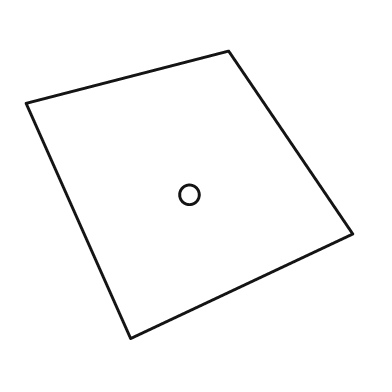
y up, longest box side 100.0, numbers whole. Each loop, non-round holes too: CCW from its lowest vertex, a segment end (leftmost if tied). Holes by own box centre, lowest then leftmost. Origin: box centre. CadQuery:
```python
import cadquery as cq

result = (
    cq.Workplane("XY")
    .moveTo(-18.0, -44.0)
    .lineTo(50.0, -12.0)
    .lineTo(12.0, 44.0)
    .lineTo(-50.0, 28.0)
    .close()
    .moveTo(0.0, 0.0)
    .circle(3.0)
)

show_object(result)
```